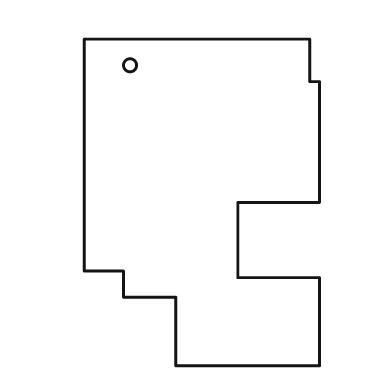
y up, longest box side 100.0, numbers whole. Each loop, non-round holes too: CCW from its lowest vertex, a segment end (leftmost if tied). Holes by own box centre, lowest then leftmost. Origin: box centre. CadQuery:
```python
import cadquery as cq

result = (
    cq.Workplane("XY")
    .moveTo(-8.0, -50.0)
    .lineTo(36.0, -50.0)
    .lineTo(36.0, -23.0)
    .lineTo(11.0, -23.0)
    .lineTo(11.0, 0.0)
    .lineTo(36.0, 0.0)
    .lineTo(36.0, 37.0)
    .lineTo(33.0, 37.0)
    .lineTo(33.0, 50.0)
    .lineTo(-36.0, 50.0)
    .lineTo(-36.0, -21.0)
    .lineTo(-24.0, -21.0)
    .lineTo(-24.0, -29.0)
    .lineTo(-8.0, -29.0)
    .close()
    .moveTo(-22.0, 42.0)
    .circle(2.0)
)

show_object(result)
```